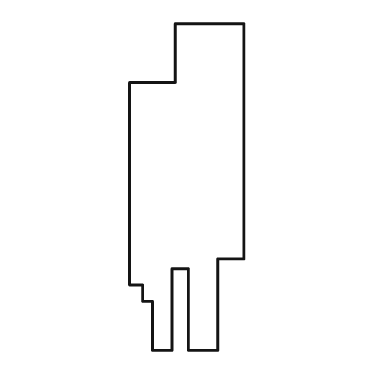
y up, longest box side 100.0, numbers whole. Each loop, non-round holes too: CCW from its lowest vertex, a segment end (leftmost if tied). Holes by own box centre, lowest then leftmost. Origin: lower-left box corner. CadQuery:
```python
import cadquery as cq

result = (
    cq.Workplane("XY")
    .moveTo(7.0, 0.0)
    .lineTo(13.0, 0.0)
    .lineTo(13.0, 25.0)
    .lineTo(18.0, 25.0)
    .lineTo(18.0, 0.0)
    .lineTo(27.0, 0.0)
    .lineTo(27.0, 28.0)
    .lineTo(35.0, 28.0)
    .lineTo(35.0, 100.0)
    .lineTo(14.0, 100.0)
    .lineTo(14.0, 82.0)
    .lineTo(0.0, 82.0)
    .lineTo(0.0, 20.0)
    .lineTo(4.0, 20.0)
    .lineTo(4.0, 15.0)
    .lineTo(7.0, 15.0)
    .close()
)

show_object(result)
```